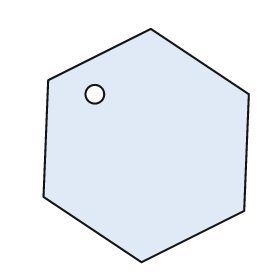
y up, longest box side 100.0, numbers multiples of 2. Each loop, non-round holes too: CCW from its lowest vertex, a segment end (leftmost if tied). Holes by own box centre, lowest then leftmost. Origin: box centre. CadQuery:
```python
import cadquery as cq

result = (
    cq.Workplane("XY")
    .moveTo(-2.0, -50.0)
    .lineTo(42.0, -28.0)
    .lineTo(44.0, 22.0)
    .lineTo(2.0, 50.0)
    .lineTo(-42.0, 28.0)
    .lineTo(-44.0, -22.0)
    .close()
    .moveTo(-22.0, 22.0)
    .circle(4.0)
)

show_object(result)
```